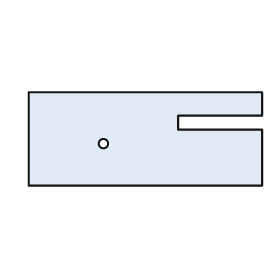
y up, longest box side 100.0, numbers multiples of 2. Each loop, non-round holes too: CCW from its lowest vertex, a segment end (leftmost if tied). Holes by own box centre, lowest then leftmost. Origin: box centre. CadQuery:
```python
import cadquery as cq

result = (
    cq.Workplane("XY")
    .moveTo(-50.0, -20.0)
    .lineTo(50.0, -20.0)
    .lineTo(50.0, 4.0)
    .lineTo(14.0, 4.0)
    .lineTo(14.0, 10.0)
    .lineTo(50.0, 10.0)
    .lineTo(50.0, 20.0)
    .lineTo(-50.0, 20.0)
    .close()
    .moveTo(-18.0, -2.0)
    .circle(2.0)
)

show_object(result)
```